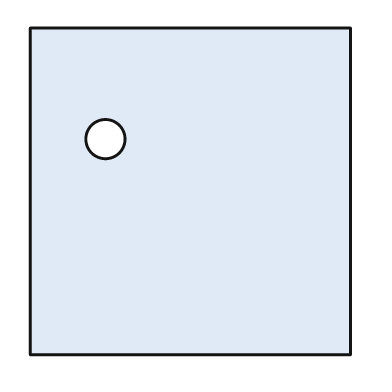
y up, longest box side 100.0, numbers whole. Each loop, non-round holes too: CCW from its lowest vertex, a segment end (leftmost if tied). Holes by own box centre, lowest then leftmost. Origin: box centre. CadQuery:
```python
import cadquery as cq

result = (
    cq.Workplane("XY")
    .moveTo(-49.0, -50.0)
    .lineTo(49.0, -50.0)
    .lineTo(49.0, 50.0)
    .lineTo(-49.0, 50.0)
    .close()
    .moveTo(-26.0, 16.0)
    .circle(6.0)
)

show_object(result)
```